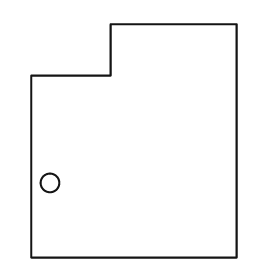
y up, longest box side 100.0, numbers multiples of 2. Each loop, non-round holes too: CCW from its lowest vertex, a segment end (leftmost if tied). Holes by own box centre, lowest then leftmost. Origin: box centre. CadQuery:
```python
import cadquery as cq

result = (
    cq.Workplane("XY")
    .moveTo(-44.0, -50.0)
    .lineTo(44.0, -50.0)
    .lineTo(44.0, 50.0)
    .lineTo(-10.0, 50.0)
    .lineTo(-10.0, 28.0)
    .lineTo(-44.0, 28.0)
    .close()
    .moveTo(-36.0, -18.0)
    .circle(4.0)
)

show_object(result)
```